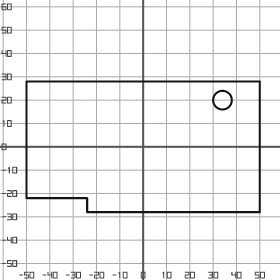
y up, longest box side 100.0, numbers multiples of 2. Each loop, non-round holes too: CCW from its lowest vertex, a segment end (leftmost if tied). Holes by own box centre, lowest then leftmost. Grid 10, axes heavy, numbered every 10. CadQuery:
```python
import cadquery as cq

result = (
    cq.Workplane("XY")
    .moveTo(-24.0, -28.0)
    .lineTo(50.0, -28.0)
    .lineTo(50.0, 28.0)
    .lineTo(-50.0, 28.0)
    .lineTo(-50.0, -22.0)
    .lineTo(-24.0, -22.0)
    .close()
    .moveTo(34.0, 20.0)
    .circle(4.0)
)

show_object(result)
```